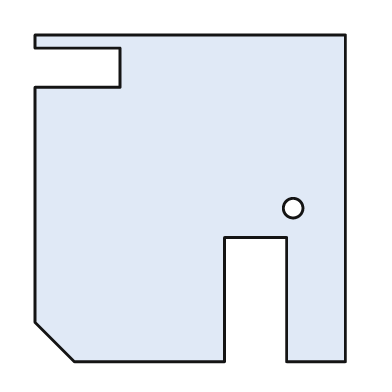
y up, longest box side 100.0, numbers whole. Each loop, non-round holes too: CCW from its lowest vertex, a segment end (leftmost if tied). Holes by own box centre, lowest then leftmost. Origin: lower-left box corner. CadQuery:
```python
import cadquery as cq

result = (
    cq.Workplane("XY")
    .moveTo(12.0, 0.0)
    .lineTo(58.0, 0.0)
    .lineTo(58.0, 38.0)
    .lineTo(77.0, 38.0)
    .lineTo(77.0, 0.0)
    .lineTo(95.0, 0.0)
    .lineTo(95.0, 100.0)
    .lineTo(0.0, 100.0)
    .lineTo(0.0, 96.0)
    .lineTo(26.0, 96.0)
    .lineTo(26.0, 84.0)
    .lineTo(0.0, 84.0)
    .lineTo(0.0, 12.0)
    .close()
    .moveTo(79.0, 47.0)
    .circle(3.0)
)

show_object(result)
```